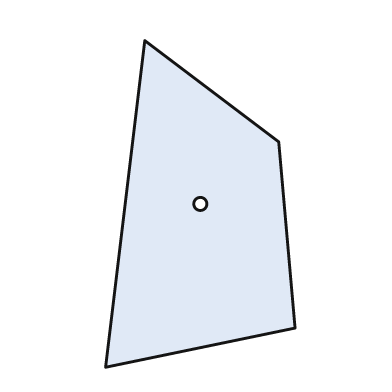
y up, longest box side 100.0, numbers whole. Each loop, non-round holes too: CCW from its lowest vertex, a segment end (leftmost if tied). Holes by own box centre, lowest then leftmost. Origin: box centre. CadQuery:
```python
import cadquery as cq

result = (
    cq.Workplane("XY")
    .moveTo(-29.0, -50.0)
    .lineTo(29.0, -38.0)
    .lineTo(24.0, 19.0)
    .lineTo(-17.0, 50.0)
    .close()
    .moveTo(0.0, 0.0)
    .circle(2.0)
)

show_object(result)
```